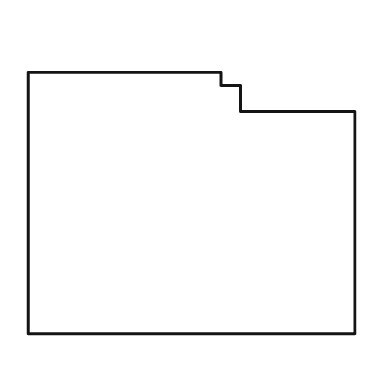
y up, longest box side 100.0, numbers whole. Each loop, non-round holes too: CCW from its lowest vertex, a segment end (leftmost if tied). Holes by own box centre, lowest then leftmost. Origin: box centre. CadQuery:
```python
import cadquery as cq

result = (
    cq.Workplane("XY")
    .moveTo(-50.0, -40.0)
    .lineTo(50.0, -40.0)
    .lineTo(50.0, 28.0)
    .lineTo(15.0, 28.0)
    .lineTo(15.0, 36.0)
    .lineTo(9.0, 36.0)
    .lineTo(9.0, 40.0)
    .lineTo(-50.0, 40.0)
    .close()
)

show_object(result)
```